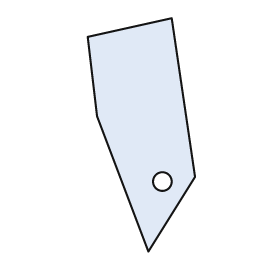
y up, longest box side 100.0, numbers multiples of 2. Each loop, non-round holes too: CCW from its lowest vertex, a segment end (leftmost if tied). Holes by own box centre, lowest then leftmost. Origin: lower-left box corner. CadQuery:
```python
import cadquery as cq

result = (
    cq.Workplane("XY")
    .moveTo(26.0, 0.0)
    .lineTo(46.0, 32.0)
    .lineTo(36.0, 100.0)
    .lineTo(0.0, 92.0)
    .lineTo(4.0, 58.0)
    .close()
    .moveTo(32.0, 30.0)
    .circle(4.0)
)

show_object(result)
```